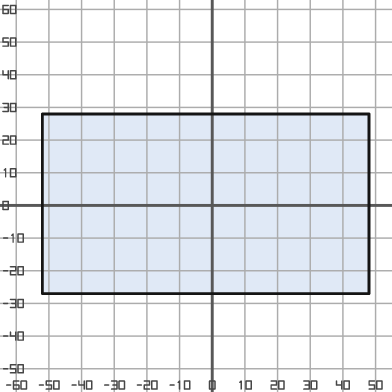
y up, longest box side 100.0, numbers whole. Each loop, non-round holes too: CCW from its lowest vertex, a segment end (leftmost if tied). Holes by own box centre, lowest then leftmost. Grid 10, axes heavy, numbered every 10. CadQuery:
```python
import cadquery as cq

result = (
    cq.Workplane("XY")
    .moveTo(-52.0, -27.0)
    .lineTo(48.0, -27.0)
    .lineTo(48.0, 28.0)
    .lineTo(-52.0, 28.0)
    .close()
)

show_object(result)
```